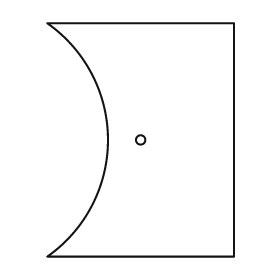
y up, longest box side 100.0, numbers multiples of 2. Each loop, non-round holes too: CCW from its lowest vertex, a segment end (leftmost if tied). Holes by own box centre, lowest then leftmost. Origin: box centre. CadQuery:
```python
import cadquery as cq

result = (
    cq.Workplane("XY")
    .moveTo(-40.0, -50.0)
    .lineTo(40.0, -50.0)
    .lineTo(40.0, 50.0)
    .lineTo(-40.0, 50.0)
    .threePointArc((-14.0, 0.0), (-40.0, -50.0))
    .close()
    .moveTo(0.0, 0.0)
    .circle(2.0)
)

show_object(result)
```